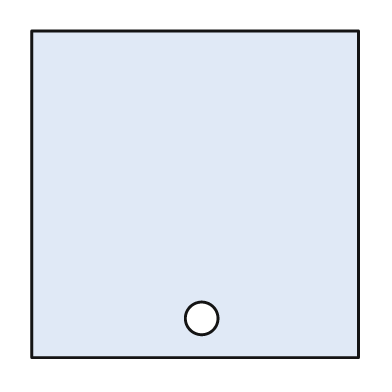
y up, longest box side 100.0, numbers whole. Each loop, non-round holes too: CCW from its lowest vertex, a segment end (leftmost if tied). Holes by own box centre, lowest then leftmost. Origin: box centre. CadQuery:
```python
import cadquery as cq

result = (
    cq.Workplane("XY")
    .moveTo(-50.0, -50.0)
    .lineTo(50.0, -50.0)
    .lineTo(50.0, 50.0)
    .lineTo(-50.0, 50.0)
    .close()
    .moveTo(2.0, -38.0)
    .circle(5.0)
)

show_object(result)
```